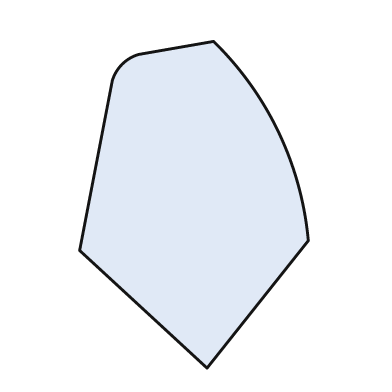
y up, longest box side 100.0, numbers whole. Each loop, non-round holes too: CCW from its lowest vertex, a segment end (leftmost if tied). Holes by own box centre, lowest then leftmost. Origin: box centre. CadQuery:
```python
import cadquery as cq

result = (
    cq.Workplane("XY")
    .moveTo(4.0, -50.0)
    .lineTo(35.0, -11.0)
    .threePointArc((26.0, 22.0), (6.0, 50.0))
    .lineTo(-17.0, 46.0)
    .threePointArc((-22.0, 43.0), (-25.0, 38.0))
    .lineTo(-35.0, -14.0)
    .close()
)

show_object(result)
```